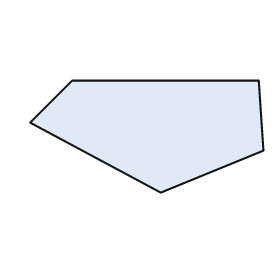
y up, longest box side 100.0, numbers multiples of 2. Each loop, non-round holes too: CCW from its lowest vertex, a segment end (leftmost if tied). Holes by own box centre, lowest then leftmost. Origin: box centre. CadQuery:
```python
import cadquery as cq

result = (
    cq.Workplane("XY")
    .moveTo(6.0, -24.0)
    .lineTo(50.0, -6.0)
    .lineTo(48.0, 24.0)
    .lineTo(-32.0, 24.0)
    .lineTo(-50.0, 6.0)
    .close()
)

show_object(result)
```